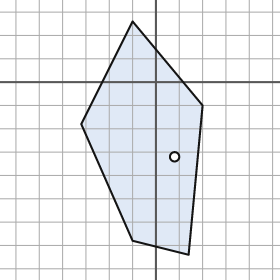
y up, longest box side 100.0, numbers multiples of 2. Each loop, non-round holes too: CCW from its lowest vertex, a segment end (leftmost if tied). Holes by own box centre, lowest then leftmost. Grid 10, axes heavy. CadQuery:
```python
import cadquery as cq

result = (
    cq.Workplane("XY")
    .moveTo(14.0, -74.0)
    .lineTo(20.0, -10.0)
    .lineTo(-10.0, 26.0)
    .lineTo(-32.0, -18.0)
    .lineTo(-10.0, -68.0)
    .close()
    .moveTo(8.0, -32.0)
    .circle(2.0)
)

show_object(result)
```